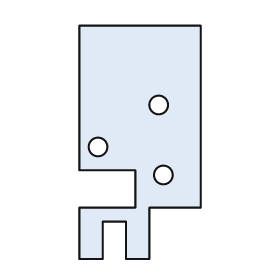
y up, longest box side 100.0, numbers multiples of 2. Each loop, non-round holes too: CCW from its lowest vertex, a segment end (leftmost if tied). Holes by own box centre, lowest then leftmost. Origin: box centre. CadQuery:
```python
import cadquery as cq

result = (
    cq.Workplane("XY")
    .moveTo(-26.0, -50.0)
    .lineTo(-16.0, -50.0)
    .lineTo(-16.0, -34.0)
    .lineTo(-6.0, -34.0)
    .lineTo(-6.0, -50.0)
    .lineTo(4.0, -50.0)
    .lineTo(4.0, -28.0)
    .lineTo(26.0, -28.0)
    .lineTo(26.0, 50.0)
    .lineTo(-26.0, 50.0)
    .lineTo(-26.0, -12.0)
    .lineTo(-2.0, -12.0)
    .lineTo(-2.0, -28.0)
    .lineTo(-26.0, -28.0)
    .close()
    .moveTo(10.0, -14.0)
    .circle(4.0)
    .moveTo(-18.0, -2.0)
    .circle(4.0)
    .moveTo(8.0, 16.0)
    .circle(4.0)
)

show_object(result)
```